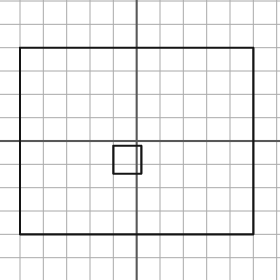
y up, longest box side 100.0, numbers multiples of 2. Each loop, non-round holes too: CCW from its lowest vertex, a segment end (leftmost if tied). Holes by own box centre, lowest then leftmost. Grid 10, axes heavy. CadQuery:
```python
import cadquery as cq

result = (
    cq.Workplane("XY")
    .moveTo(-50.0, -40.0)
    .lineTo(50.0, -40.0)
    .lineTo(50.0, 40.0)
    .lineTo(-50.0, 40.0)
    .close()
    .moveTo(-10.0, -14.0)
    .lineTo(2.0, -14.0)
    .lineTo(2.0, -2.0)
    .lineTo(-10.0, -2.0)
    .close()
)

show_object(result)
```